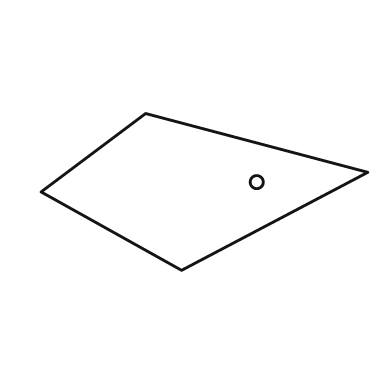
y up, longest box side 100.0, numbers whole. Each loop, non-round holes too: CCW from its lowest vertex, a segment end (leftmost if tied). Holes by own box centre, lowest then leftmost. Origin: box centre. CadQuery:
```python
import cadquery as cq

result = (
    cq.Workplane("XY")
    .moveTo(-7.0, -24.0)
    .lineTo(50.0, 6.0)
    .lineTo(-18.0, 24.0)
    .lineTo(-50.0, 0.0)
    .close()
    .moveTo(16.0, 3.0)
    .circle(2.0)
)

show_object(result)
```